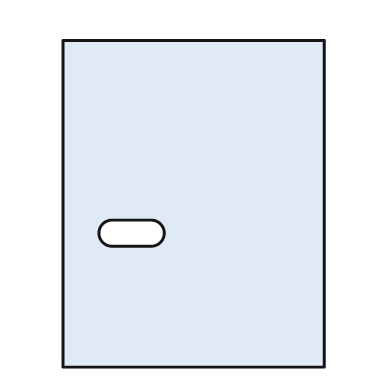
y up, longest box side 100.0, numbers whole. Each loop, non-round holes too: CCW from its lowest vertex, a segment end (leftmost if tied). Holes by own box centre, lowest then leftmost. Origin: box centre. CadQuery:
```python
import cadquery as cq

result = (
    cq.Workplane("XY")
    .moveTo(-40.0, -50.0)
    .lineTo(40.0, -50.0)
    .lineTo(40.0, 50.0)
    .lineTo(-40.0, 50.0)
    .close()
    .moveTo(-25.0, -13.0)
    .lineTo(-13.0, -13.0)
    .threePointArc((-9.0, -9.0), (-13.0, -5.0))
    .lineTo(-25.0, -5.0)
    .threePointArc((-29.0, -9.0), (-25.0, -13.0))
    .close()
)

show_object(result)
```